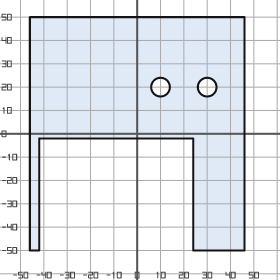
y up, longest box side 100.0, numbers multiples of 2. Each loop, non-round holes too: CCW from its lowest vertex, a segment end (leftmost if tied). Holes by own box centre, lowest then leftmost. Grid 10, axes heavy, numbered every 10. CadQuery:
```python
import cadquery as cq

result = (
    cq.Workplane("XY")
    .moveTo(-46.0, -50.0)
    .lineTo(-42.0, -50.0)
    .lineTo(-42.0, -2.0)
    .lineTo(24.0, -2.0)
    .lineTo(24.0, -50.0)
    .lineTo(46.0, -50.0)
    .lineTo(46.0, 50.0)
    .lineTo(-46.0, 50.0)
    .close()
    .moveTo(10.0, 20.0)
    .circle(4.0)
    .moveTo(30.0, 20.0)
    .circle(4.0)
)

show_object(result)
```